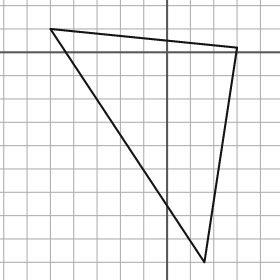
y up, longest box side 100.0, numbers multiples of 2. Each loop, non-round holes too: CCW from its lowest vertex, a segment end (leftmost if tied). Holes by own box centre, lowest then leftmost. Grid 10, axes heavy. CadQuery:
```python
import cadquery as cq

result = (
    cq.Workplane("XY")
    .moveTo(16.0, -90.0)
    .lineTo(30.0, 2.0)
    .lineTo(-50.0, 10.0)
    .close()
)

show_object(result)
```